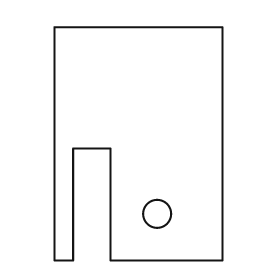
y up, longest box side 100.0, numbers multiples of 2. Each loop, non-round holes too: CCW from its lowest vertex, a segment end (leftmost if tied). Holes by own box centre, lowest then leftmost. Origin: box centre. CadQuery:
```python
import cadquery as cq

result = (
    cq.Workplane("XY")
    .moveTo(-36.0, -50.0)
    .lineTo(-28.0, -50.0)
    .lineTo(-28.0, -2.0)
    .lineTo(-12.0, -2.0)
    .lineTo(-12.0, -50.0)
    .lineTo(36.0, -50.0)
    .lineTo(36.0, 50.0)
    .lineTo(-36.0, 50.0)
    .close()
    .moveTo(8.0, -30.0)
    .circle(6.0)
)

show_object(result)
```